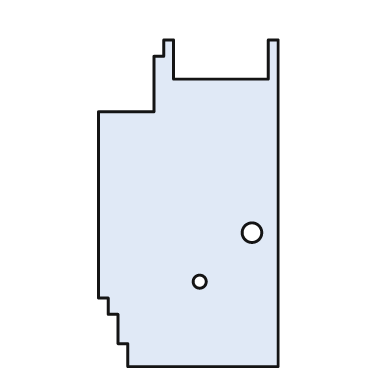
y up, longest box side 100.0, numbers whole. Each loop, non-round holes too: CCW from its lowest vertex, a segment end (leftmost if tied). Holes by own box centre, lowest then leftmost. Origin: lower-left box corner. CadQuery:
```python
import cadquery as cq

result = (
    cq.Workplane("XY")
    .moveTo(9.0, 0.0)
    .lineTo(55.0, 0.0)
    .lineTo(55.0, 100.0)
    .lineTo(52.0, 100.0)
    .lineTo(52.0, 88.0)
    .lineTo(23.0, 88.0)
    .lineTo(23.0, 100.0)
    .lineTo(20.0, 100.0)
    .lineTo(20.0, 95.0)
    .lineTo(17.0, 95.0)
    .lineTo(17.0, 78.0)
    .lineTo(0.0, 78.0)
    .lineTo(0.0, 21.0)
    .lineTo(3.0, 21.0)
    .lineTo(3.0, 16.0)
    .lineTo(6.0, 16.0)
    .lineTo(6.0, 7.0)
    .lineTo(9.0, 7.0)
    .close()
    .moveTo(31.0, 26.0)
    .circle(2.0)
    .moveTo(47.0, 41.0)
    .circle(3.0)
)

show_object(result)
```